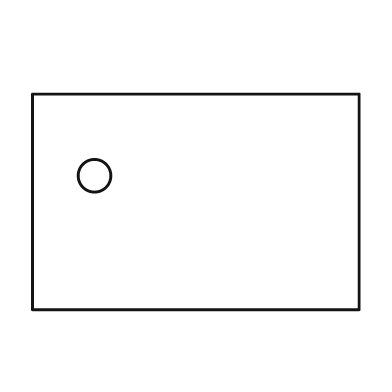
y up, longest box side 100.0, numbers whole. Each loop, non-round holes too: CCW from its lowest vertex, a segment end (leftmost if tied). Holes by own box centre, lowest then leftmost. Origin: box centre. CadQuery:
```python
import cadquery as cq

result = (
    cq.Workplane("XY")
    .moveTo(-50.0, -33.0)
    .lineTo(50.0, -33.0)
    .lineTo(50.0, 33.0)
    .lineTo(-50.0, 33.0)
    .close()
    .moveTo(-31.0, 8.0)
    .circle(5.0)
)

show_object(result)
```